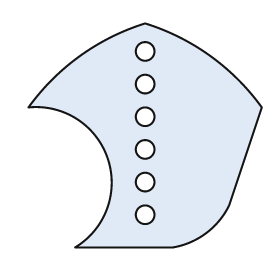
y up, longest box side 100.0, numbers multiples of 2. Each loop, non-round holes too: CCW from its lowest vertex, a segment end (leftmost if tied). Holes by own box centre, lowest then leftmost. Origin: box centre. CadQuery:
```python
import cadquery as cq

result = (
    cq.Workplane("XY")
    .moveTo(-30.0, -48.0)
    .lineTo(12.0, -48.0)
    .threePointArc((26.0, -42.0), (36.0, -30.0))
    .lineTo(50.0, 12.0)
    .threePointArc((28.0, 34.0), (0.0, 48.0))
    .threePointArc((-28.0, 34.0), (-50.0, 12.0))
    .threePointArc((-16.0, -10.0), (-30.0, -48.0))
    .close()
    .moveTo(0.0, -34.0)
    .circle(4.0)
    .moveTo(0.0, -20.0)
    .circle(4.0)
    .moveTo(0.0, -6.0)
    .circle(4.0)
    .moveTo(0.0, 8.0)
    .circle(4.0)
    .moveTo(0.0, 22.0)
    .circle(4.0)
    .moveTo(0.0, 36.0)
    .circle(4.0)
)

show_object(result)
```